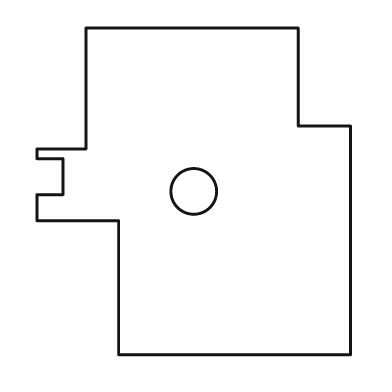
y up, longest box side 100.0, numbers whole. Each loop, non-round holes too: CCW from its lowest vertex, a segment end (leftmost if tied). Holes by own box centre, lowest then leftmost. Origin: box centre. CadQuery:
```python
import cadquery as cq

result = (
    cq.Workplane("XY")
    .moveTo(-23.0, -50.0)
    .lineTo(48.0, -50.0)
    .lineTo(48.0, 20.0)
    .lineTo(32.0, 20.0)
    .lineTo(32.0, 50.0)
    .lineTo(-33.0, 50.0)
    .lineTo(-33.0, 13.0)
    .lineTo(-48.0, 13.0)
    .lineTo(-48.0, 10.0)
    .lineTo(-40.0, 10.0)
    .lineTo(-40.0, -1.0)
    .lineTo(-48.0, -1.0)
    .lineTo(-48.0, -9.0)
    .lineTo(-23.0, -9.0)
    .close()
    .moveTo(0.0, 0.0)
    .circle(7.0)
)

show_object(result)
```